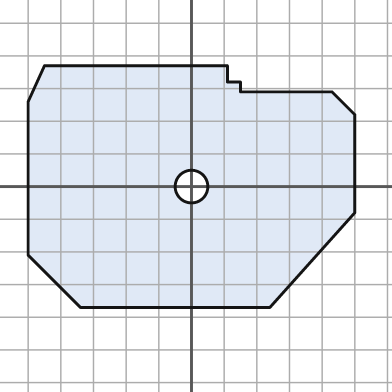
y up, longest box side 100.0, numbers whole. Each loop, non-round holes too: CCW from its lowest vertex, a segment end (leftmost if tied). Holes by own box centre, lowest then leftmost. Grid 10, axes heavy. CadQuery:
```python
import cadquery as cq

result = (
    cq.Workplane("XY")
    .moveTo(-34.0, -37.0)
    .lineTo(24.0, -37.0)
    .lineTo(50.0, -8.0)
    .lineTo(50.0, 22.0)
    .lineTo(43.0, 29.0)
    .lineTo(15.0, 29.0)
    .lineTo(15.0, 32.0)
    .lineTo(11.0, 32.0)
    .lineTo(11.0, 37.0)
    .lineTo(-45.0, 37.0)
    .lineTo(-50.0, 26.0)
    .lineTo(-50.0, -21.0)
    .close()
    .moveTo(0.0, 0.0)
    .circle(5.0)
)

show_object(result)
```